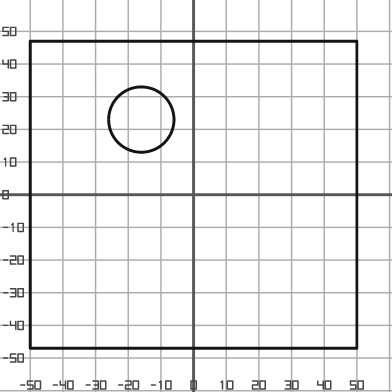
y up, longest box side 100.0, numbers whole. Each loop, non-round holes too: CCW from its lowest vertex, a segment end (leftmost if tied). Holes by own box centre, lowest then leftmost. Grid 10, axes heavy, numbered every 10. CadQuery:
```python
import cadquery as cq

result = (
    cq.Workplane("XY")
    .moveTo(-50.0, -47.0)
    .lineTo(50.0, -47.0)
    .lineTo(50.0, 47.0)
    .lineTo(-50.0, 47.0)
    .close()
    .moveTo(-16.0, 23.0)
    .circle(10.0)
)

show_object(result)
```